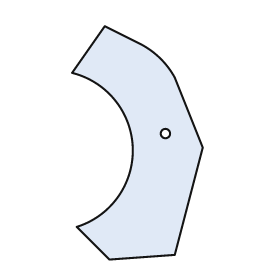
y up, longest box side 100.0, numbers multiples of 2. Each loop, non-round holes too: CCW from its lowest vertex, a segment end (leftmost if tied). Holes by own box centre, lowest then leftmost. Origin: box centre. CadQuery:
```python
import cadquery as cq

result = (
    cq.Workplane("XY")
    .moveTo(-12.0, -50.0)
    .lineTo(16.0, -48.0)
    .lineTo(28.0, -2.0)
    .lineTo(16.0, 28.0)
    .threePointArc((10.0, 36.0), (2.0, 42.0))
    .lineTo(-14.0, 50.0)
    .lineTo(-28.0, 30.0)
    .threePointArc((-2.0, -2.0), (-26.0, -36.0))
    .close()
    .moveTo(12.0, 4.0)
    .circle(2.0)
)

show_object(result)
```